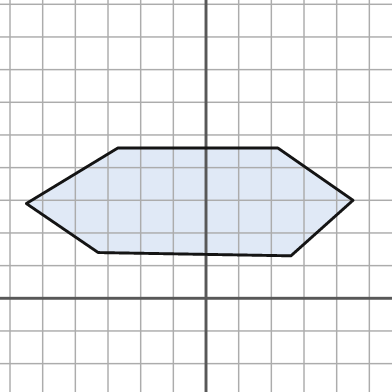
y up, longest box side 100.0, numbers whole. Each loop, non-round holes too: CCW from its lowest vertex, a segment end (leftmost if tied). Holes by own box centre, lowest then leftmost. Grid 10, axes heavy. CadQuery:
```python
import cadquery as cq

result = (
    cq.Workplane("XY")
    .moveTo(26.0, 13.0)
    .lineTo(45.0, 30.0)
    .lineTo(22.0, 46.0)
    .lineTo(-27.0, 46.0)
    .lineTo(-55.0, 29.0)
    .lineTo(-33.0, 14.0)
    .close()
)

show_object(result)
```